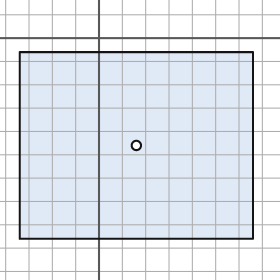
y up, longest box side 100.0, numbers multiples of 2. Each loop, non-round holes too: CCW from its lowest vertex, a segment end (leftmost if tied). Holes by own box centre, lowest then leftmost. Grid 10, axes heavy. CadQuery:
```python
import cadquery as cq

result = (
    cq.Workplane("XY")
    .moveTo(-34.0, -86.0)
    .lineTo(66.0, -86.0)
    .lineTo(66.0, -6.0)
    .lineTo(-34.0, -6.0)
    .close()
    .moveTo(16.0, -46.0)
    .circle(2.0)
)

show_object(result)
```